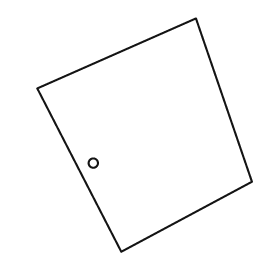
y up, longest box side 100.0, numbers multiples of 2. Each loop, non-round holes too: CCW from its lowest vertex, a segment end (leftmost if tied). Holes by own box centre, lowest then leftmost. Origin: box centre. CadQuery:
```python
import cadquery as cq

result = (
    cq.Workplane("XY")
    .moveTo(-10.0, -50.0)
    .lineTo(46.0, -20.0)
    .lineTo(22.0, 50.0)
    .lineTo(-46.0, 20.0)
    .close()
    .moveTo(-22.0, -12.0)
    .circle(2.0)
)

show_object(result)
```